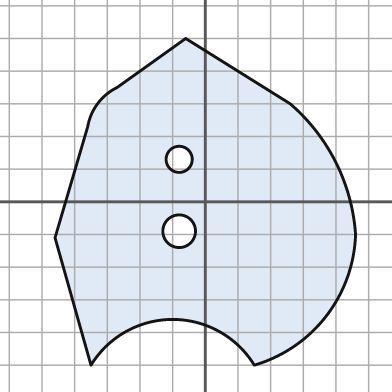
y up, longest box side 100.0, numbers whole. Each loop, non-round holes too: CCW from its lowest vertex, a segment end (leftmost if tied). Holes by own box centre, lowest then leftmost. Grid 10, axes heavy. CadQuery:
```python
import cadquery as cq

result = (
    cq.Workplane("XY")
    .moveTo(-35.0, -50.0)
    .threePointArc((-10.0, -36.0), (15.0, -50.0))
    .threePointArc((37.0, -35.0), (46.0, -10.0))
    .threePointArc((40.0, 12.0), (26.0, 30.0))
    .lineTo(-6.0, 50.0)
    .lineTo(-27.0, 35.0)
    .threePointArc((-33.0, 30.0), (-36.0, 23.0))
    .lineTo(-46.0, -11.0)
    .close()
    .moveTo(-8.0, -9.0)
    .circle(5.0)
    .moveTo(-8.0, 13.0)
    .circle(4.0)
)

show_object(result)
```